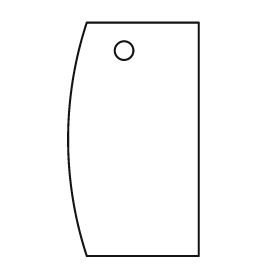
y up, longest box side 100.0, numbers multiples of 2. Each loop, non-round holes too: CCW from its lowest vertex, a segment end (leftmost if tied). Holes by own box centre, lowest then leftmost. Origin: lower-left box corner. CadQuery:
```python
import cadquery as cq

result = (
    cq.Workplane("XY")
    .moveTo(8.0, 0.0)
    .lineTo(56.0, 0.0)
    .lineTo(56.0, 100.0)
    .lineTo(8.0, 100.0)
    .threePointArc((0.0, 50.0), (8.0, 0.0))
    .close()
    .moveTo(24.0, 88.0)
    .circle(4.0)
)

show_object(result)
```